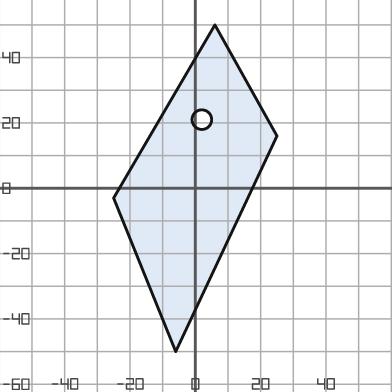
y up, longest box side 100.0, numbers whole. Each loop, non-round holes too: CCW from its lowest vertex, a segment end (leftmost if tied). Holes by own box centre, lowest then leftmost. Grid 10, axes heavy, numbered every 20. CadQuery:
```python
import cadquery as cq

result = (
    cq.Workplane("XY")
    .moveTo(-6.0, -50.0)
    .lineTo(25.0, 16.0)
    .lineTo(6.0, 50.0)
    .lineTo(-25.0, -3.0)
    .close()
    .moveTo(2.0, 21.0)
    .circle(3.0)
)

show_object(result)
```